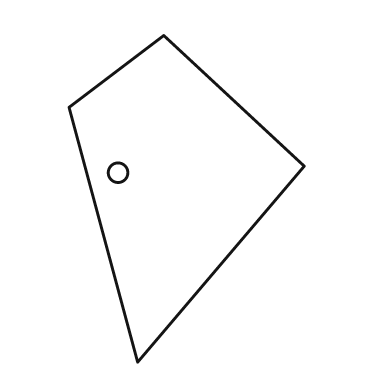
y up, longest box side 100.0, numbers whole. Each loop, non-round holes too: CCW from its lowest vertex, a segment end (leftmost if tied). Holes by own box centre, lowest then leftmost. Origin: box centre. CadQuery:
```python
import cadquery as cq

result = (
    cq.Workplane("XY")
    .moveTo(-15.0, -50.0)
    .lineTo(36.0, 10.0)
    .lineTo(-7.0, 50.0)
    .lineTo(-36.0, 28.0)
    .close()
    .moveTo(-21.0, 8.0)
    .circle(3.0)
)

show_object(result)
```